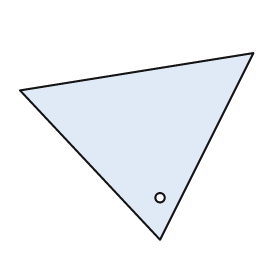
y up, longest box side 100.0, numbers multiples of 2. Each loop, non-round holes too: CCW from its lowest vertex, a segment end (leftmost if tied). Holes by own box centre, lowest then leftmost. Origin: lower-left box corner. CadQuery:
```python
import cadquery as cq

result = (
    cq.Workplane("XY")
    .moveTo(60.0, 0.0)
    .lineTo(100.0, 80.0)
    .lineTo(0.0, 64.0)
    .close()
    .moveTo(60.0, 18.0)
    .circle(2.0)
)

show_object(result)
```